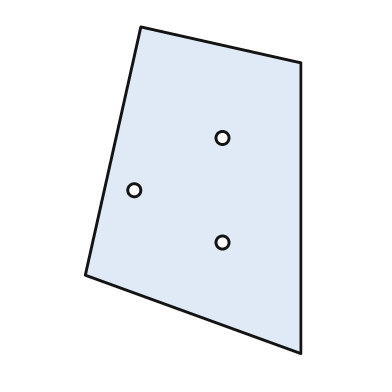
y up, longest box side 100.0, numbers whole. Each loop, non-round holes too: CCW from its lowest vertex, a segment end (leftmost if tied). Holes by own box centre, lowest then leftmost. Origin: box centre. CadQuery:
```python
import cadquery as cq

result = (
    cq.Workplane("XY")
    .moveTo(33.0, -50.0)
    .lineTo(33.0, 39.0)
    .lineTo(-16.0, 50.0)
    .lineTo(-33.0, -26.0)
    .close()
    .moveTo(9.0, -16.0)
    .circle(2.0)
    .moveTo(-18.0, 0.0)
    .circle(2.0)
    .moveTo(9.0, 16.0)
    .circle(2.0)
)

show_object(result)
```